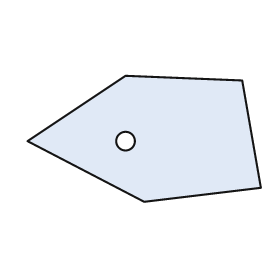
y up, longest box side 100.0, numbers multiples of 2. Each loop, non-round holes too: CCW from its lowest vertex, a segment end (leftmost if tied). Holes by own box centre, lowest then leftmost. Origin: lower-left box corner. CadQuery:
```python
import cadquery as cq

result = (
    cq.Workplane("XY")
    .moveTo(50.0, 0.0)
    .lineTo(100.0, 6.0)
    .lineTo(92.0, 52.0)
    .lineTo(42.0, 54.0)
    .lineTo(0.0, 26.0)
    .close()
    .moveTo(42.0, 26.0)
    .circle(4.0)
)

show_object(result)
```